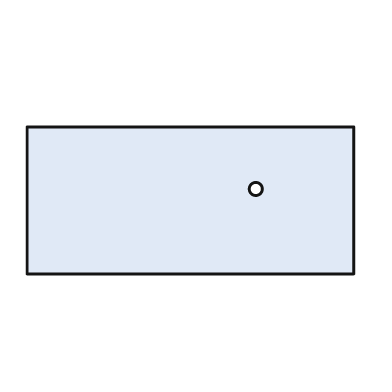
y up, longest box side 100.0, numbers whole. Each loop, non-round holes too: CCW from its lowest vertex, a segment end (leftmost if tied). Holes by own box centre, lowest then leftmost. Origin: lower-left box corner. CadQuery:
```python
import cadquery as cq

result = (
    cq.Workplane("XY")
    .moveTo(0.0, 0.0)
    .lineTo(100.0, 0.0)
    .lineTo(100.0, 45.0)
    .lineTo(0.0, 45.0)
    .close()
    .moveTo(70.0, 26.0)
    .circle(2.0)
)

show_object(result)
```